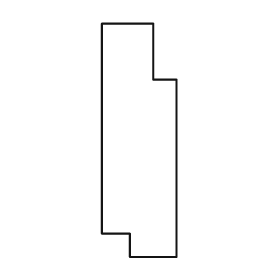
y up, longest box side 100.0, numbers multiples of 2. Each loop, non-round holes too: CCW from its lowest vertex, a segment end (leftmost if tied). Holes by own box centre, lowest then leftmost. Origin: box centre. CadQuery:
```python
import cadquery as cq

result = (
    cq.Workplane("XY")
    .moveTo(-4.0, -50.0)
    .lineTo(16.0, -50.0)
    .lineTo(16.0, 26.0)
    .lineTo(6.0, 26.0)
    .lineTo(6.0, 50.0)
    .lineTo(-16.0, 50.0)
    .lineTo(-16.0, -40.0)
    .lineTo(-4.0, -40.0)
    .close()
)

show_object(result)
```